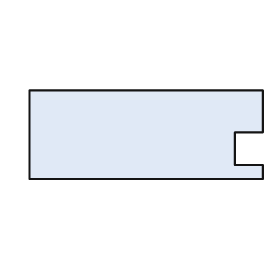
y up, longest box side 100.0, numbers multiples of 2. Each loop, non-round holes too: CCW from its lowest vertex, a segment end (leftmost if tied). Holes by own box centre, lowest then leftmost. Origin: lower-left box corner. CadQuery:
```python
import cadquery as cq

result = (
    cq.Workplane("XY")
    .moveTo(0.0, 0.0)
    .lineTo(100.0, 0.0)
    .lineTo(100.0, 6.0)
    .lineTo(88.0, 6.0)
    .lineTo(88.0, 20.0)
    .lineTo(100.0, 20.0)
    .lineTo(100.0, 38.0)
    .lineTo(0.0, 38.0)
    .close()
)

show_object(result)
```